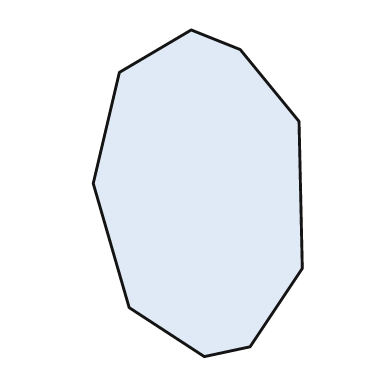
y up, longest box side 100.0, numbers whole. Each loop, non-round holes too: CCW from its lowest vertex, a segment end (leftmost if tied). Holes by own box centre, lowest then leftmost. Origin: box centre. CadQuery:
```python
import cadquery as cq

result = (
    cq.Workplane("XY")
    .moveTo(2.0, -50.0)
    .lineTo(16.0, -47.0)
    .lineTo(32.0, -23.0)
    .lineTo(31.0, 22.0)
    .lineTo(13.0, 44.0)
    .lineTo(-2.0, 50.0)
    .lineTo(-24.0, 37.0)
    .lineTo(-32.0, 3.0)
    .lineTo(-21.0, -35.0)
    .close()
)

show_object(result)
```